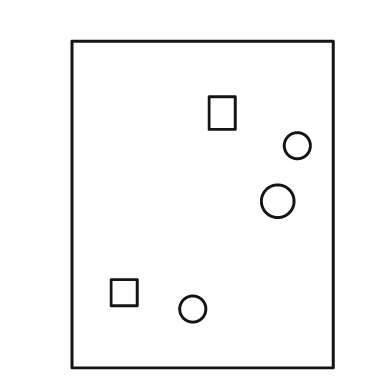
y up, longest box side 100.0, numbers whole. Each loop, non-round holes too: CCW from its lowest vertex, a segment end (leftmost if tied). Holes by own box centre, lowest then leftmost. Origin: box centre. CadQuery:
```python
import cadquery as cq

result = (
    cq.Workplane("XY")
    .moveTo(-40.0, -50.0)
    .lineTo(40.0, -50.0)
    .lineTo(40.0, 50.0)
    .lineTo(-40.0, 50.0)
    .close()
    .moveTo(-3.0, -32.0)
    .circle(4.0)
    .moveTo(-28.0, -31.0)
    .lineTo(-20.0, -31.0)
    .lineTo(-20.0, -23.0)
    .lineTo(-28.0, -23.0)
    .close()
    .moveTo(23.0, 1.0)
    .circle(5.0)
    .moveTo(29.0, 18.0)
    .circle(4.0)
    .moveTo(2.0, 23.0)
    .lineTo(10.0, 23.0)
    .lineTo(10.0, 33.0)
    .lineTo(2.0, 33.0)
    .close()
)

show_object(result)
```